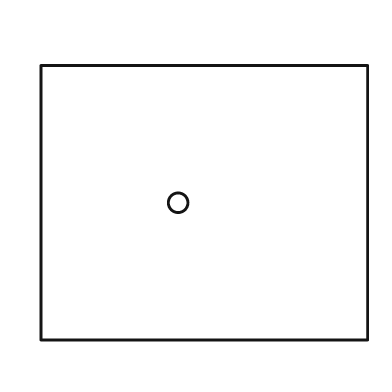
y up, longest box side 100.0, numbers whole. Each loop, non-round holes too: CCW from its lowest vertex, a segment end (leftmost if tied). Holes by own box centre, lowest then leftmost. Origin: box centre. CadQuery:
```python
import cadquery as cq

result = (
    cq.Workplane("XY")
    .moveTo(-50.0, -42.0)
    .lineTo(50.0, -42.0)
    .lineTo(50.0, 42.0)
    .lineTo(-50.0, 42.0)
    .close()
    .moveTo(-8.0, 0.0)
    .circle(3.0)
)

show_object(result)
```